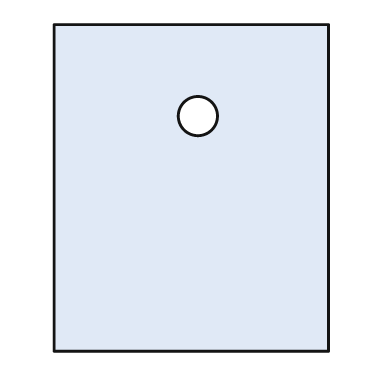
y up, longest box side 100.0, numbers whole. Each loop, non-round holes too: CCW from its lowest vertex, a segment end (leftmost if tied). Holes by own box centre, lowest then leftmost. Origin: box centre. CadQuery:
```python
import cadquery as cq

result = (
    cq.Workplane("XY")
    .moveTo(-42.0, -50.0)
    .lineTo(42.0, -50.0)
    .lineTo(42.0, 50.0)
    .lineTo(-42.0, 50.0)
    .close()
    .moveTo(2.0, 22.0)
    .circle(6.0)
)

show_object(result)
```